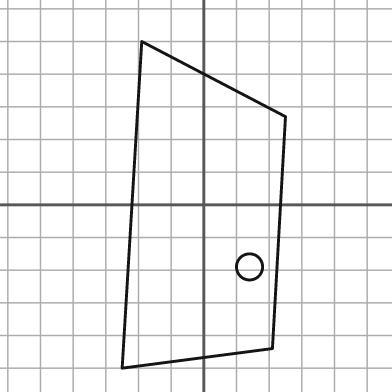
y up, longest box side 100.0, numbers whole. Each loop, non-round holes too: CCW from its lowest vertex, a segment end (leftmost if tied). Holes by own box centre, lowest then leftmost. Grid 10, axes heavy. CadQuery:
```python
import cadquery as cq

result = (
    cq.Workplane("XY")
    .moveTo(-25.0, -50.0)
    .lineTo(21.0, -44.0)
    .lineTo(25.0, 27.0)
    .lineTo(-19.0, 50.0)
    .close()
    .moveTo(14.0, -19.0)
    .circle(4.0)
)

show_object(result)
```